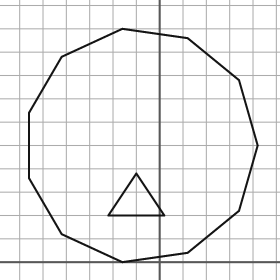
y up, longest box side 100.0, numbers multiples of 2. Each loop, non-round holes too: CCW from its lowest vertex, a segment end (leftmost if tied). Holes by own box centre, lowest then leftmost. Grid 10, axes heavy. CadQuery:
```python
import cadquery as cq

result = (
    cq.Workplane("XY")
    .moveTo(-16.0, 0.0)
    .lineTo(12.0, 4.0)
    .lineTo(34.0, 22.0)
    .lineTo(42.0, 50.0)
    .lineTo(34.0, 78.0)
    .lineTo(12.0, 96.0)
    .lineTo(-16.0, 100.0)
    .lineTo(-42.0, 88.0)
    .lineTo(-56.0, 64.0)
    .lineTo(-56.0, 36.0)
    .lineTo(-42.0, 12.0)
    .close()
    .moveTo(-22.0, 20.0)
    .lineTo(2.0, 20.0)
    .lineTo(-10.0, 38.0)
    .close()
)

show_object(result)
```